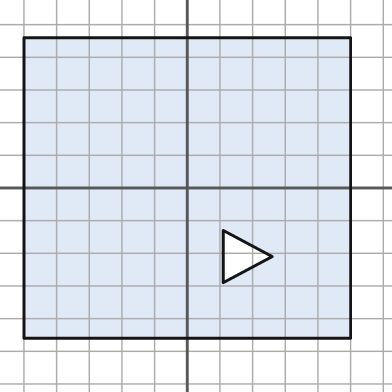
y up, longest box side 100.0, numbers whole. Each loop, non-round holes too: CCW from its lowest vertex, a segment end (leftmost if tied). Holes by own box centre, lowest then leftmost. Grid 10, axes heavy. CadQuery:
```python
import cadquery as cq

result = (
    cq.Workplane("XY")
    .moveTo(-50.0, -46.0)
    .lineTo(50.0, -46.0)
    .lineTo(50.0, 46.0)
    .lineTo(-50.0, 46.0)
    .close()
    .moveTo(11.0, -29.0)
    .lineTo(26.0, -21.0)
    .lineTo(11.0, -13.0)
    .close()
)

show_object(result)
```